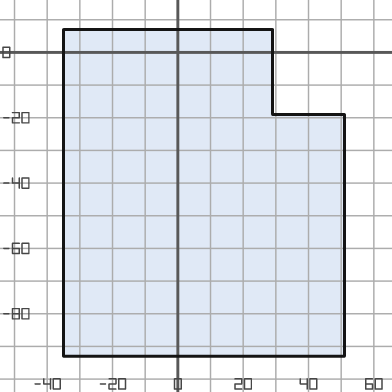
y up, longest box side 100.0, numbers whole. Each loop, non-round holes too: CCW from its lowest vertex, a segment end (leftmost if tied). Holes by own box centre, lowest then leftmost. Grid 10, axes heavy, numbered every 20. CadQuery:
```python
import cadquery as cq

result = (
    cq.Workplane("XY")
    .moveTo(-35.0, -93.0)
    .lineTo(51.0, -93.0)
    .lineTo(51.0, -19.0)
    .lineTo(29.0, -19.0)
    .lineTo(29.0, 7.0)
    .lineTo(-35.0, 7.0)
    .close()
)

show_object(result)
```